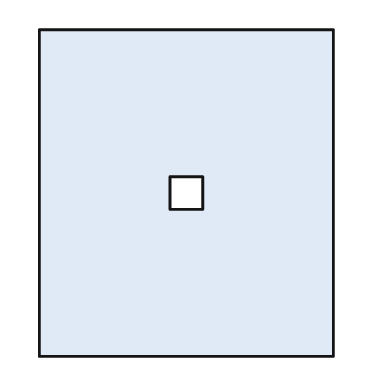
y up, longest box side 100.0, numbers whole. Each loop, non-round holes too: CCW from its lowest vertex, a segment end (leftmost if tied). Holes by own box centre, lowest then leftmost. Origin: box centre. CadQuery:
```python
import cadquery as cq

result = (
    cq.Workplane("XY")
    .moveTo(-45.0, -50.0)
    .lineTo(45.0, -50.0)
    .lineTo(45.0, 50.0)
    .lineTo(-45.0, 50.0)
    .close()
    .moveTo(-5.0, -5.0)
    .lineTo(5.0, -5.0)
    .lineTo(5.0, 5.0)
    .lineTo(-5.0, 5.0)
    .close()
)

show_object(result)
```